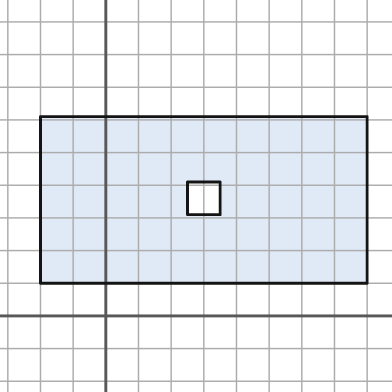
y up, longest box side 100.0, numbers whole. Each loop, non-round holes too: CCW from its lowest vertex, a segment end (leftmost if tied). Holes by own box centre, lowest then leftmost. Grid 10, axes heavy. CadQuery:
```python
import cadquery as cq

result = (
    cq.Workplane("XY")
    .moveTo(-20.0, 10.0)
    .lineTo(80.0, 10.0)
    .lineTo(80.0, 61.0)
    .lineTo(-20.0, 61.0)
    .close()
    .moveTo(25.0, 31.0)
    .lineTo(35.0, 31.0)
    .lineTo(35.0, 41.0)
    .lineTo(25.0, 41.0)
    .close()
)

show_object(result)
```